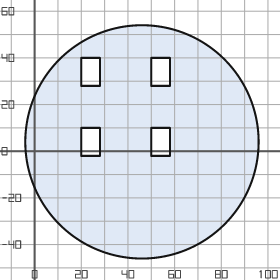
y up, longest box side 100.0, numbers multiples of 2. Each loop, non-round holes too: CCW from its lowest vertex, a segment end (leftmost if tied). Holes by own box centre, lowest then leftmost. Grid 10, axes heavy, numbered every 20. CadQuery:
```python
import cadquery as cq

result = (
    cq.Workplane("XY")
    .moveTo(46.0, 4.0)
    .circle(50.0)
    .moveTo(20.0, -2.0)
    .lineTo(28.0, -2.0)
    .lineTo(28.0, 10.0)
    .lineTo(20.0, 10.0)
    .close()
    .moveTo(50.0, -2.0)
    .lineTo(58.0, -2.0)
    .lineTo(58.0, 10.0)
    .lineTo(50.0, 10.0)
    .close()
    .moveTo(20.0, 28.0)
    .lineTo(28.0, 28.0)
    .lineTo(28.0, 40.0)
    .lineTo(20.0, 40.0)
    .close()
    .moveTo(50.0, 28.0)
    .lineTo(58.0, 28.0)
    .lineTo(58.0, 40.0)
    .lineTo(50.0, 40.0)
    .close()
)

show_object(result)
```